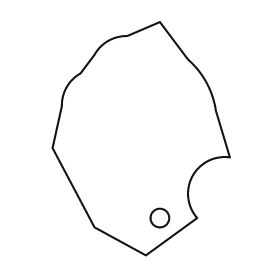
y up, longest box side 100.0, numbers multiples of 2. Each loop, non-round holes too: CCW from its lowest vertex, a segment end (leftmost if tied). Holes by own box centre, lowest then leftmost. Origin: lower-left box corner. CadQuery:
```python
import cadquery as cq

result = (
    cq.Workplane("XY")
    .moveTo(40.0, 0.0)
    .lineTo(62.0, 16.0)
    .threePointArc((60.0, 34.0), (76.0, 42.0))
    .lineTo(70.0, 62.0)
    .threePointArc((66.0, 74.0), (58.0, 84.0))
    .lineTo(46.0, 100.0)
    .lineTo(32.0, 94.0)
    .threePointArc((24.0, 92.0), (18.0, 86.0))
    .lineTo(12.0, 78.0)
    .threePointArc((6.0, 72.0), (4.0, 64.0))
    .lineTo(0.0, 46.0)
    .lineTo(18.0, 12.0)
    .close()
    .moveTo(46.0, 16.0)
    .circle(4.0)
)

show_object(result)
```